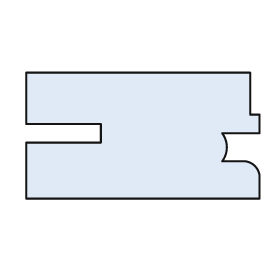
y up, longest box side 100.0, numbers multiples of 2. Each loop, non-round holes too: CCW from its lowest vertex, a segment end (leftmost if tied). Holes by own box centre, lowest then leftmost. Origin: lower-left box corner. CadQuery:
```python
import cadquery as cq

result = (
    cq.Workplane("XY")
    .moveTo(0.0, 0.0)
    .lineTo(100.0, 0.0)
    .lineTo(100.0, 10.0)
    .threePointArc((98.0, 14.0), (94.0, 16.0))
    .lineTo(84.0, 16.0)
    .threePointArc((86.0, 22.0), (84.0, 28.0))
    .lineTo(100.0, 28.0)
    .lineTo(100.0, 36.0)
    .lineTo(96.0, 36.0)
    .lineTo(96.0, 54.0)
    .lineTo(0.0, 54.0)
    .lineTo(0.0, 32.0)
    .lineTo(32.0, 32.0)
    .lineTo(32.0, 24.0)
    .lineTo(0.0, 24.0)
    .close()
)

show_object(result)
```